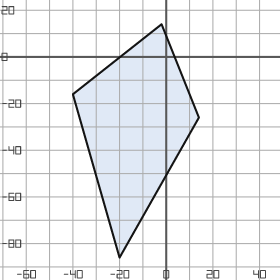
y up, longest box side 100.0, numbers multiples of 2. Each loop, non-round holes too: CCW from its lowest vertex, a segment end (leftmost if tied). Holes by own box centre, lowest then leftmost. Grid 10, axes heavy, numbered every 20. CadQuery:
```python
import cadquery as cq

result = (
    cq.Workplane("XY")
    .moveTo(-20.0, -86.0)
    .lineTo(14.0, -26.0)
    .lineTo(-2.0, 14.0)
    .lineTo(-40.0, -16.0)
    .close()
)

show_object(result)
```